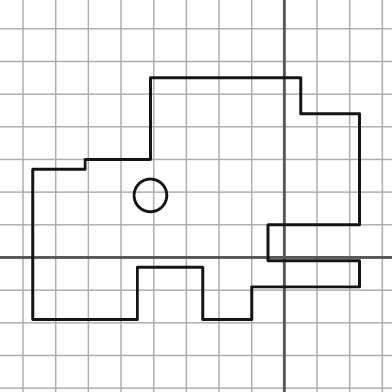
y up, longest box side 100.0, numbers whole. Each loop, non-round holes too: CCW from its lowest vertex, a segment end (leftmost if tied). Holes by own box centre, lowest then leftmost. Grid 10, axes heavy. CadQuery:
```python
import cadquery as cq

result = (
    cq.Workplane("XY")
    .moveTo(-77.0, -19.0)
    .lineTo(-45.0, -19.0)
    .lineTo(-45.0, -3.0)
    .lineTo(-25.0, -3.0)
    .lineTo(-25.0, -19.0)
    .lineTo(-10.0, -19.0)
    .lineTo(-10.0, -9.0)
    .lineTo(23.0, -9.0)
    .lineTo(23.0, -1.0)
    .lineTo(-5.0, -1.0)
    .lineTo(-5.0, 10.0)
    .lineTo(23.0, 10.0)
    .lineTo(23.0, 44.0)
    .lineTo(5.0, 44.0)
    .lineTo(5.0, 55.0)
    .lineTo(-41.0, 55.0)
    .lineTo(-41.0, 30.0)
    .lineTo(-61.0, 30.0)
    .lineTo(-61.0, 27.0)
    .lineTo(-77.0, 27.0)
    .close()
    .moveTo(-41.0, 19.0)
    .circle(5.0)
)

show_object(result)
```